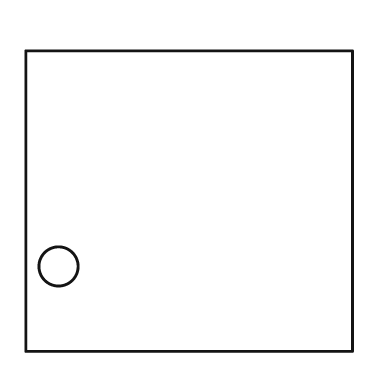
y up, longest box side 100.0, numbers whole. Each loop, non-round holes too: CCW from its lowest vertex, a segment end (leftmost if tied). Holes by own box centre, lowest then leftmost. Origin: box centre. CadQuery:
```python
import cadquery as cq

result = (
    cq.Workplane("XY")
    .moveTo(-50.0, -46.0)
    .lineTo(50.0, -46.0)
    .lineTo(50.0, 46.0)
    .lineTo(-50.0, 46.0)
    .close()
    .moveTo(-40.0, -20.0)
    .circle(6.0)
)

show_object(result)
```